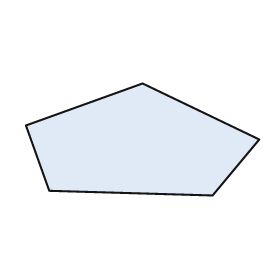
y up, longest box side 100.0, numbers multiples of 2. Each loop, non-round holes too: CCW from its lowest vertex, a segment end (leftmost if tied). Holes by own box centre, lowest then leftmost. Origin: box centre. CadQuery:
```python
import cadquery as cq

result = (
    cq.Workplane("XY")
    .moveTo(30.0, -24.0)
    .lineTo(50.0, 0.0)
    .lineTo(0.0, 24.0)
    .lineTo(-50.0, 6.0)
    .lineTo(-40.0, -22.0)
    .close()
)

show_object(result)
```